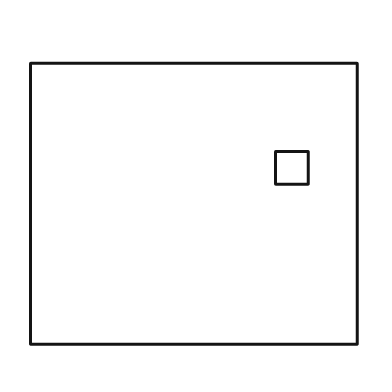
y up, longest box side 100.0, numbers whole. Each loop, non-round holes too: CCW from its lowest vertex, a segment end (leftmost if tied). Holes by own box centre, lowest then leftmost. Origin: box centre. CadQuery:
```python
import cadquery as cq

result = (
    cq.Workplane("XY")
    .moveTo(-50.0, -43.0)
    .lineTo(50.0, -43.0)
    .lineTo(50.0, 43.0)
    .lineTo(-50.0, 43.0)
    .close()
    .moveTo(25.0, 6.0)
    .lineTo(35.0, 6.0)
    .lineTo(35.0, 16.0)
    .lineTo(25.0, 16.0)
    .close()
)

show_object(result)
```